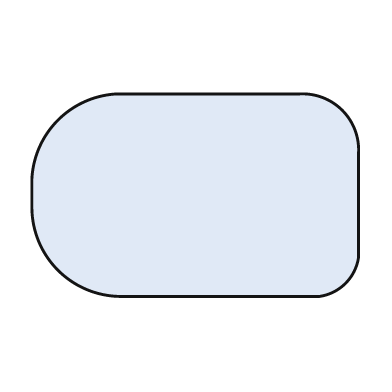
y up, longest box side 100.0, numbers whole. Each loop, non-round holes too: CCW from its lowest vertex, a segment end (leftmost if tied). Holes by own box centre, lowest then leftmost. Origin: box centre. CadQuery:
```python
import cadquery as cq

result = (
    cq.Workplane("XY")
    .moveTo(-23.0, -31.0)
    .lineTo(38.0, -31.0)
    .threePointArc((46.0, -27.0), (50.0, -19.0))
    .lineTo(50.0, 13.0)
    .threePointArc((45.0, 26.0), (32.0, 31.0))
    .lineTo(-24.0, 31.0)
    .threePointArc((-42.0, 23.0), (-50.0, 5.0))
    .lineTo(-50.0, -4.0)
    .threePointArc((-42.0, -23.0), (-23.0, -31.0))
    .close()
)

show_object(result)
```